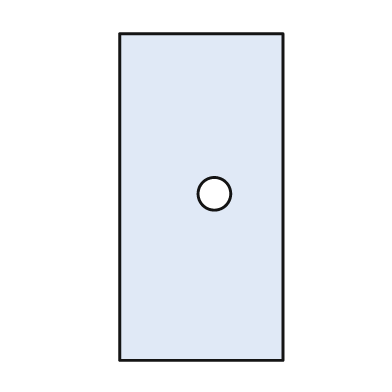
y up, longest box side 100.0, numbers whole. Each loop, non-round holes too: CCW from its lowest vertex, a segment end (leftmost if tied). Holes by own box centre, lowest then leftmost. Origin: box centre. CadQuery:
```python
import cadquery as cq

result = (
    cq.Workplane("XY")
    .moveTo(-25.0, -50.0)
    .lineTo(25.0, -50.0)
    .lineTo(25.0, 50.0)
    .lineTo(-25.0, 50.0)
    .close()
    .moveTo(4.0, 1.0)
    .circle(5.0)
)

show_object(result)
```